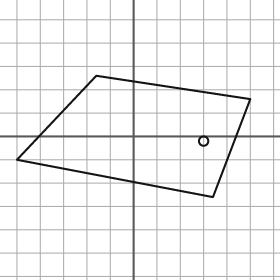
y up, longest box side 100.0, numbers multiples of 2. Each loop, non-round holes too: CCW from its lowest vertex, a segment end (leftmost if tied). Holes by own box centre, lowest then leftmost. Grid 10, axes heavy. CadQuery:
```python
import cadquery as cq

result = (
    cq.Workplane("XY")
    .moveTo(34.0, -26.0)
    .lineTo(50.0, 16.0)
    .lineTo(-16.0, 26.0)
    .lineTo(-50.0, -10.0)
    .close()
    .moveTo(30.0, -2.0)
    .circle(2.0)
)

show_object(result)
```